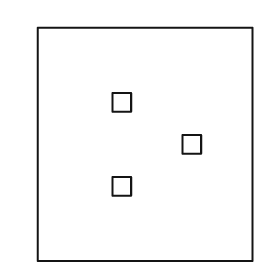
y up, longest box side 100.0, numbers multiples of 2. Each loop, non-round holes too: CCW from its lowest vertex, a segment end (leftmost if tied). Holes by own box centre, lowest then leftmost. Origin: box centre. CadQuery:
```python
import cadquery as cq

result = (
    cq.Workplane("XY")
    .moveTo(-46.0, -50.0)
    .lineTo(46.0, -50.0)
    .lineTo(46.0, 50.0)
    .lineTo(-46.0, 50.0)
    .close()
    .moveTo(-14.0, -22.0)
    .lineTo(-6.0, -22.0)
    .lineTo(-6.0, -14.0)
    .lineTo(-14.0, -14.0)
    .close()
    .moveTo(16.0, -4.0)
    .lineTo(24.0, -4.0)
    .lineTo(24.0, 4.0)
    .lineTo(16.0, 4.0)
    .close()
    .moveTo(-14.0, 14.0)
    .lineTo(-6.0, 14.0)
    .lineTo(-6.0, 22.0)
    .lineTo(-14.0, 22.0)
    .close()
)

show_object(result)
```